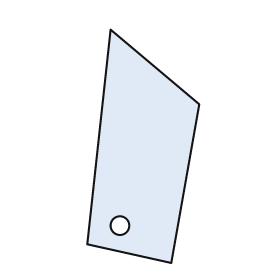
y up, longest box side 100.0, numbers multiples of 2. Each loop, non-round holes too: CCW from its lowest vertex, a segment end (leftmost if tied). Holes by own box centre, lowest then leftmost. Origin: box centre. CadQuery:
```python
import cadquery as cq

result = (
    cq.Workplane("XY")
    .moveTo(12.0, -50.0)
    .lineTo(24.0, 18.0)
    .lineTo(-14.0, 50.0)
    .lineTo(-24.0, -42.0)
    .close()
    .moveTo(-10.0, -34.0)
    .circle(4.0)
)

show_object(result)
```